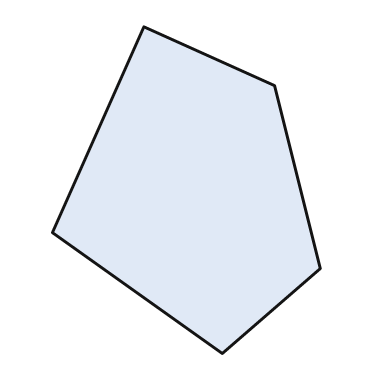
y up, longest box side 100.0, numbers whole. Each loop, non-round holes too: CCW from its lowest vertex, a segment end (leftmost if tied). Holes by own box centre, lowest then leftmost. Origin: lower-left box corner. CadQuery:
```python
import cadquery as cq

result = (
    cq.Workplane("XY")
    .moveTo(52.0, 0.0)
    .lineTo(82.0, 26.0)
    .lineTo(68.0, 82.0)
    .lineTo(28.0, 100.0)
    .lineTo(0.0, 37.0)
    .close()
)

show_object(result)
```